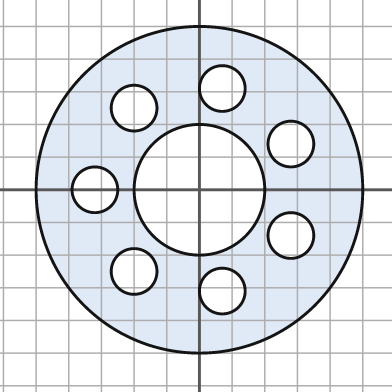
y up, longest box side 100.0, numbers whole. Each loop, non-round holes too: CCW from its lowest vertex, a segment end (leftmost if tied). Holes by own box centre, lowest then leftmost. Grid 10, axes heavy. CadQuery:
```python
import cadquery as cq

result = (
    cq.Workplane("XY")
    .moveTo(0.0, 0.0)
    .circle(50.0)
    .moveTo(7.0, -31.0)
    .circle(7.0)
    .moveTo(-20.0, -25.0)
    .circle(7.0)
    .moveTo(28.0, -14.0)
    .circle(7.0)
    .moveTo(-32.0, 0.0)
    .circle(7.0)
    .moveTo(0.0, 0.0)
    .circle(20.0)
    .moveTo(28.0, 14.0)
    .circle(7.0)
    .moveTo(-20.0, 25.0)
    .circle(7.0)
    .moveTo(7.0, 31.0)
    .circle(7.0)
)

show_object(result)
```